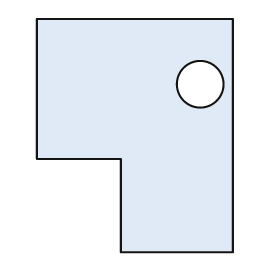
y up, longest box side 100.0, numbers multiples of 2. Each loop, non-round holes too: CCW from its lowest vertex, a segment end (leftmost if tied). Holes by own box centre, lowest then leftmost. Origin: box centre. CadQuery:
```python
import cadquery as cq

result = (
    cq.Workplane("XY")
    .moveTo(-6.0, -50.0)
    .lineTo(42.0, -50.0)
    .lineTo(42.0, 50.0)
    .lineTo(-42.0, 50.0)
    .lineTo(-42.0, -10.0)
    .lineTo(-6.0, -10.0)
    .close()
    .moveTo(28.0, 22.0)
    .circle(10.0)
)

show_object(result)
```